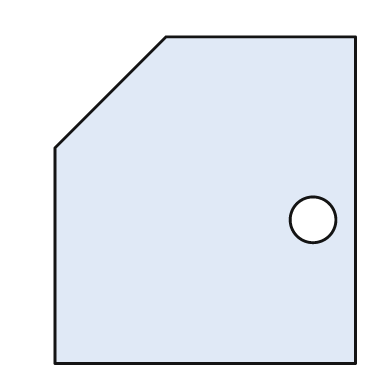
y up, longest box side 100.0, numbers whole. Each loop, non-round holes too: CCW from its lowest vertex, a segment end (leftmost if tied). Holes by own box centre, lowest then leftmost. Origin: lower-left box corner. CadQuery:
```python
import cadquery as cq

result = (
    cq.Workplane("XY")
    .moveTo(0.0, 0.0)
    .lineTo(92.0, 0.0)
    .lineTo(92.0, 100.0)
    .lineTo(34.0, 100.0)
    .lineTo(0.0, 66.0)
    .close()
    .moveTo(79.0, 44.0)
    .circle(7.0)
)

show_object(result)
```